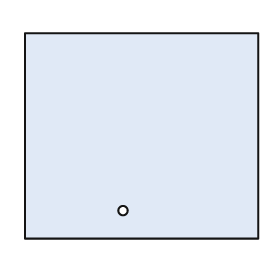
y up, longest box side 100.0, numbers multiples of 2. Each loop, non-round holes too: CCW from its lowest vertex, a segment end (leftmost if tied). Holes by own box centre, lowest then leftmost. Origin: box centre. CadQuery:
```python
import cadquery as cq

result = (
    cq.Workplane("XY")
    .moveTo(-50.0, -44.0)
    .lineTo(50.0, -44.0)
    .lineTo(50.0, 44.0)
    .lineTo(-50.0, 44.0)
    .close()
    .moveTo(-8.0, -32.0)
    .circle(2.0)
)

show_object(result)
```